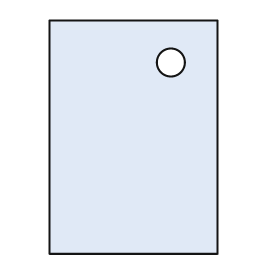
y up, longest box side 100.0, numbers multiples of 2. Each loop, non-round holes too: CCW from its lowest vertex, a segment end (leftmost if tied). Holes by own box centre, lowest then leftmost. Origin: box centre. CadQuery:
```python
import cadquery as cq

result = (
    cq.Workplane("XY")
    .moveTo(-36.0, -50.0)
    .lineTo(36.0, -50.0)
    .lineTo(36.0, 50.0)
    .lineTo(-36.0, 50.0)
    .close()
    .moveTo(16.0, 32.0)
    .circle(6.0)
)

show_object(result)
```